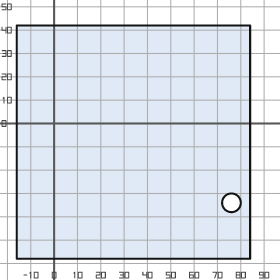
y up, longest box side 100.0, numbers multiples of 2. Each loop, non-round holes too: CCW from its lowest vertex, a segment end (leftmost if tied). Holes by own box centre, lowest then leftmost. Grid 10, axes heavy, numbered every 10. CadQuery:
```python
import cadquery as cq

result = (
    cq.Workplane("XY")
    .moveTo(-16.0, -58.0)
    .lineTo(84.0, -58.0)
    .lineTo(84.0, 42.0)
    .lineTo(-16.0, 42.0)
    .close()
    .moveTo(76.0, -34.0)
    .circle(4.0)
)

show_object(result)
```